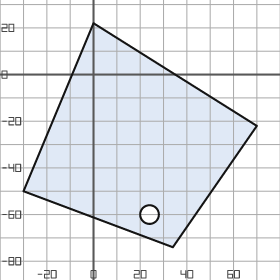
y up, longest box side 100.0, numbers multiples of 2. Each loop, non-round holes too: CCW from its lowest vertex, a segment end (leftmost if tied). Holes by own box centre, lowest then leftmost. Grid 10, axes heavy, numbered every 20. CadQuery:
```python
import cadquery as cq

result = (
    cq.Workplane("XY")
    .moveTo(34.0, -74.0)
    .lineTo(70.0, -22.0)
    .lineTo(0.0, 22.0)
    .lineTo(-30.0, -50.0)
    .close()
    .moveTo(24.0, -60.0)
    .circle(4.0)
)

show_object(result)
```